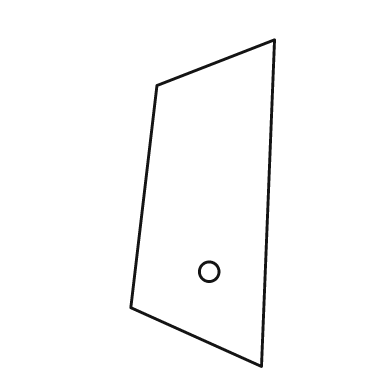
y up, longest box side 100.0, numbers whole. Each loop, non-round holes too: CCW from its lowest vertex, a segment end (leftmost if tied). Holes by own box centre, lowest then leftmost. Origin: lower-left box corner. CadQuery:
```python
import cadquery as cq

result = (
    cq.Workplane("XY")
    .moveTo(40.0, 0.0)
    .lineTo(44.0, 100.0)
    .lineTo(8.0, 86.0)
    .lineTo(0.0, 18.0)
    .close()
    .moveTo(24.0, 29.0)
    .circle(3.0)
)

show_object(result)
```